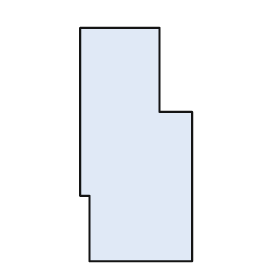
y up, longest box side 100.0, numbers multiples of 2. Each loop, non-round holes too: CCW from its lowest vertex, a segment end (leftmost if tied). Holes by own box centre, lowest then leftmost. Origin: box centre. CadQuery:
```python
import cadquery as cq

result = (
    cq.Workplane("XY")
    .moveTo(-20.0, -50.0)
    .lineTo(24.0, -50.0)
    .lineTo(24.0, 14.0)
    .lineTo(10.0, 14.0)
    .lineTo(10.0, 50.0)
    .lineTo(-24.0, 50.0)
    .lineTo(-24.0, -22.0)
    .lineTo(-20.0, -22.0)
    .close()
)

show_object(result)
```